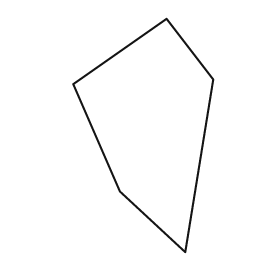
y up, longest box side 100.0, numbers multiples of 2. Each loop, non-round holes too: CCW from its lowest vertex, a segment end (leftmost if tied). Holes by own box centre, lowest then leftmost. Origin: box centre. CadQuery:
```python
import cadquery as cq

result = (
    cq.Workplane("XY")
    .moveTo(18.0, -50.0)
    .lineTo(30.0, 24.0)
    .lineTo(10.0, 50.0)
    .lineTo(-30.0, 22.0)
    .lineTo(-10.0, -24.0)
    .close()
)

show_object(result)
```